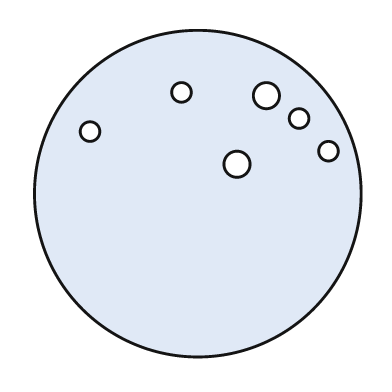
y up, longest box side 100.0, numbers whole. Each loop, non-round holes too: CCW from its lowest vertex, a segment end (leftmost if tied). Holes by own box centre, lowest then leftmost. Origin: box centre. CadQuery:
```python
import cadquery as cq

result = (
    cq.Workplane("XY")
    .moveTo(0.0, 0.0)
    .circle(50.0)
    .moveTo(12.0, 9.0)
    .circle(4.0)
    .moveTo(40.0, 13.0)
    .circle(3.0)
    .moveTo(-33.0, 19.0)
    .circle(3.0)
    .moveTo(31.0, 23.0)
    .circle(3.0)
    .moveTo(21.0, 30.0)
    .circle(4.0)
    .moveTo(-5.0, 31.0)
    .circle(3.0)
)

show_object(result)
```